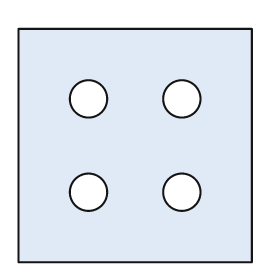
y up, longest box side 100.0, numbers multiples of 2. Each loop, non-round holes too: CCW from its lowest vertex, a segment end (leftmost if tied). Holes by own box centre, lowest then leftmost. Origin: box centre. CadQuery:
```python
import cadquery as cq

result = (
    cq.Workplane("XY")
    .moveTo(-50.0, -50.0)
    .lineTo(50.0, -50.0)
    .lineTo(50.0, 50.0)
    .lineTo(-50.0, 50.0)
    .close()
    .moveTo(-20.0, -20.0)
    .circle(8.0)
    .moveTo(20.0, -20.0)
    .circle(8.0)
    .moveTo(-20.0, 20.0)
    .circle(8.0)
    .moveTo(20.0, 20.0)
    .circle(8.0)
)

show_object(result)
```